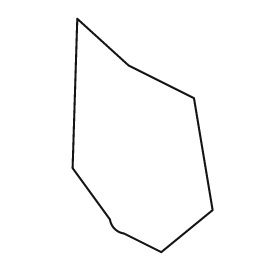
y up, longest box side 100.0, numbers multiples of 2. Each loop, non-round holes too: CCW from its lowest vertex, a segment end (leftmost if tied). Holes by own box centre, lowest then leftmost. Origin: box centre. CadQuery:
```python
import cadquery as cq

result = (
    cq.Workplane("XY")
    .moveTo(8.0, -50.0)
    .lineTo(30.0, -32.0)
    .lineTo(22.0, 16.0)
    .lineTo(-6.0, 30.0)
    .lineTo(-28.0, 50.0)
    .lineTo(-30.0, -14.0)
    .lineTo(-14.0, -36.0)
    .threePointArc((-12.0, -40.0), (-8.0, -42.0))
    .close()
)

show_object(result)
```